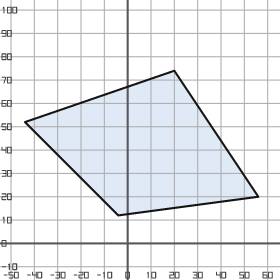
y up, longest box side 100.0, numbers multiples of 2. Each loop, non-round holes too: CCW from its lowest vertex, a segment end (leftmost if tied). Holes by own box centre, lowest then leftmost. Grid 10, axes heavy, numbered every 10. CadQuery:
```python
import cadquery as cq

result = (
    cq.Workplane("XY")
    .moveTo(-4.0, 12.0)
    .lineTo(56.0, 20.0)
    .lineTo(20.0, 74.0)
    .lineTo(-44.0, 52.0)
    .close()
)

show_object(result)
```